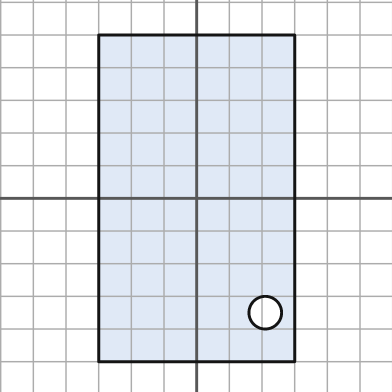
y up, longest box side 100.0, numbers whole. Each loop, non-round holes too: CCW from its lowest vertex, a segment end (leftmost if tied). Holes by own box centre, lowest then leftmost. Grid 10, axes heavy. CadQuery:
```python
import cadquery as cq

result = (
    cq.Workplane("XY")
    .moveTo(-30.0, -50.0)
    .lineTo(30.0, -50.0)
    .lineTo(30.0, 50.0)
    .lineTo(-30.0, 50.0)
    .close()
    .moveTo(21.0, -35.0)
    .circle(5.0)
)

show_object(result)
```